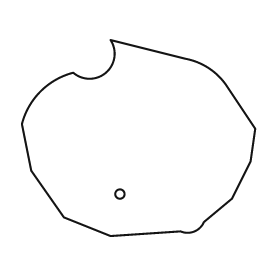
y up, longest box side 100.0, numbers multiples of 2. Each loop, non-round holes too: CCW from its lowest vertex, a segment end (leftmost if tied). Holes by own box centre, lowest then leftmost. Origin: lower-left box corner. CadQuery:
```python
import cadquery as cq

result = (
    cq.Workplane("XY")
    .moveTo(38.0, 0.0)
    .lineTo(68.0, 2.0)
    .threePointArc((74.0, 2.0), (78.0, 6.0))
    .lineTo(90.0, 16.0)
    .lineTo(98.0, 32.0)
    .lineTo(100.0, 46.0)
    .lineTo(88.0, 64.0)
    .threePointArc((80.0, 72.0), (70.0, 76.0))
    .lineTo(38.0, 84.0)
    .threePointArc((36.0, 70.0), (22.0, 70.0))
    .threePointArc((8.0, 62.0), (0.0, 48.0))
    .lineTo(4.0, 28.0)
    .lineTo(18.0, 8.0)
    .close()
    .moveTo(42.0, 18.0)
    .circle(2.0)
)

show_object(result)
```